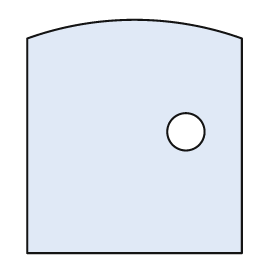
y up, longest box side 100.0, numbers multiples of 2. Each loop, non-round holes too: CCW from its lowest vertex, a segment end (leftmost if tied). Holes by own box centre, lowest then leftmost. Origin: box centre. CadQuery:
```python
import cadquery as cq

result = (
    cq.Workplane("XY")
    .moveTo(-46.0, -50.0)
    .lineTo(46.0, -50.0)
    .lineTo(46.0, 42.0)
    .threePointArc((0.0, 50.0), (-46.0, 42.0))
    .close()
    .moveTo(22.0, 2.0)
    .circle(8.0)
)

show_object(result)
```